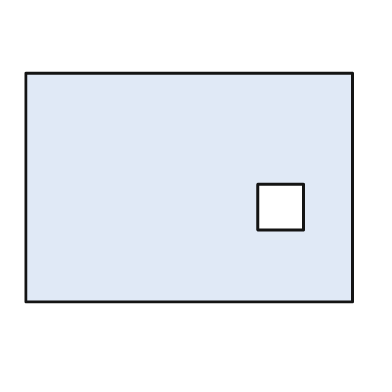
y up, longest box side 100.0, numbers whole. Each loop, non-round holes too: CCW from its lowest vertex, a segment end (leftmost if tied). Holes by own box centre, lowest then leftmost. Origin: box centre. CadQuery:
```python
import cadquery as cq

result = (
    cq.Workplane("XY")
    .moveTo(-50.0, -35.0)
    .lineTo(50.0, -35.0)
    .lineTo(50.0, 35.0)
    .lineTo(-50.0, 35.0)
    .close()
    .moveTo(21.0, -13.0)
    .lineTo(35.0, -13.0)
    .lineTo(35.0, 1.0)
    .lineTo(21.0, 1.0)
    .close()
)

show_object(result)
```